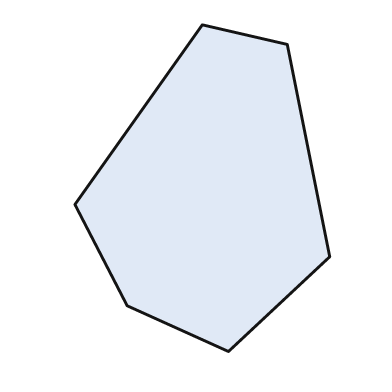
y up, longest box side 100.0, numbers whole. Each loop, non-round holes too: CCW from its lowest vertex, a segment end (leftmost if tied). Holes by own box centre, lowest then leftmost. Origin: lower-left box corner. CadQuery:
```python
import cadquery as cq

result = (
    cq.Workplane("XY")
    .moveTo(47.0, 0.0)
    .lineTo(78.0, 29.0)
    .lineTo(65.0, 94.0)
    .lineTo(39.0, 100.0)
    .lineTo(0.0, 45.0)
    .lineTo(16.0, 14.0)
    .close()
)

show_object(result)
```